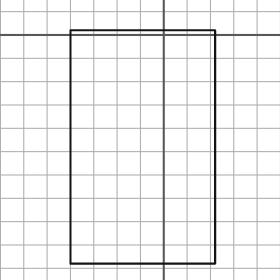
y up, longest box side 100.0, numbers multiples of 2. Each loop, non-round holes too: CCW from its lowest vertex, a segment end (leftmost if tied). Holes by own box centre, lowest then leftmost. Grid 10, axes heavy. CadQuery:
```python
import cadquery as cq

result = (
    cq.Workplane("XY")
    .moveTo(-40.0, -98.0)
    .lineTo(22.0, -98.0)
    .lineTo(22.0, 2.0)
    .lineTo(-40.0, 2.0)
    .close()
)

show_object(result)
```